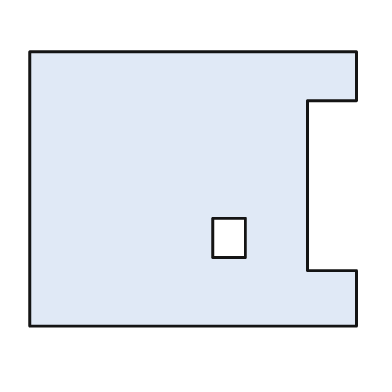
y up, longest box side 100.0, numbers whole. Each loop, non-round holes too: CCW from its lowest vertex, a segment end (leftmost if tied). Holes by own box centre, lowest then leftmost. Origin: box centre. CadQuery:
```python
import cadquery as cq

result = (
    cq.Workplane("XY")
    .moveTo(-50.0, -42.0)
    .lineTo(50.0, -42.0)
    .lineTo(50.0, -25.0)
    .lineTo(35.0, -25.0)
    .lineTo(35.0, 27.0)
    .lineTo(50.0, 27.0)
    .lineTo(50.0, 42.0)
    .lineTo(-50.0, 42.0)
    .close()
    .moveTo(6.0, -21.0)
    .lineTo(16.0, -21.0)
    .lineTo(16.0, -9.0)
    .lineTo(6.0, -9.0)
    .close()
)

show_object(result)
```